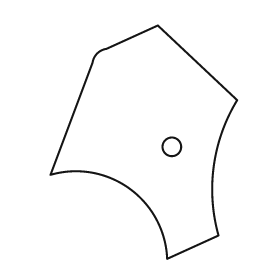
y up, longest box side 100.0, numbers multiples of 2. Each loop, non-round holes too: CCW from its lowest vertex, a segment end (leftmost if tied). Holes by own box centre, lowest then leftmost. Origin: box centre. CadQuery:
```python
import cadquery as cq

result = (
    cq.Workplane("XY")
    .moveTo(10.0, -50.0)
    .lineTo(32.0, -40.0)
    .threePointArc((30.0, -10.0), (40.0, 18.0))
    .lineTo(6.0, 50.0)
    .lineTo(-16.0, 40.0)
    .threePointArc((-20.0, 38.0), (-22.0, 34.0))
    .lineTo(-40.0, -14.0)
    .threePointArc((-6.0, -20.0), (10.0, -50.0))
    .close()
    .moveTo(12.0, -2.0)
    .circle(4.0)
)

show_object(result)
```